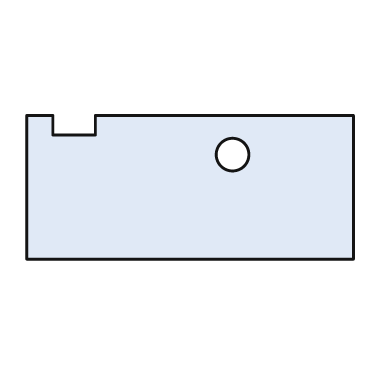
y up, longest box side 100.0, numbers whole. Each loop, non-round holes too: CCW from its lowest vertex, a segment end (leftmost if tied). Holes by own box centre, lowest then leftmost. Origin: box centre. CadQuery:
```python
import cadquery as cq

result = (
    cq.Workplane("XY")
    .moveTo(-50.0, -22.0)
    .lineTo(50.0, -22.0)
    .lineTo(50.0, 22.0)
    .lineTo(-29.0, 22.0)
    .lineTo(-29.0, 16.0)
    .lineTo(-42.0, 16.0)
    .lineTo(-42.0, 22.0)
    .lineTo(-50.0, 22.0)
    .close()
    .moveTo(13.0, 10.0)
    .circle(5.0)
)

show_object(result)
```